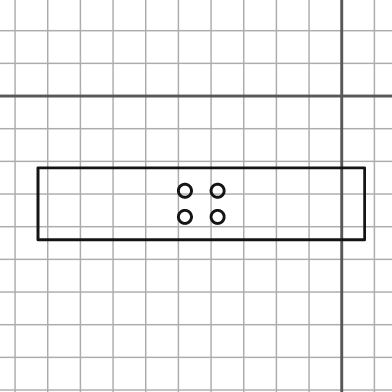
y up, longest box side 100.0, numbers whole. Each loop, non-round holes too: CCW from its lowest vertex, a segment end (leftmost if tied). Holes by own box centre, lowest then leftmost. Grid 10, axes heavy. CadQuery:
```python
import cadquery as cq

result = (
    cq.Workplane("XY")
    .moveTo(-93.0, -44.0)
    .lineTo(7.0, -44.0)
    .lineTo(7.0, -22.0)
    .lineTo(-93.0, -22.0)
    .close()
    .moveTo(-48.0, -37.0)
    .circle(2.0)
    .moveTo(-38.0, -37.0)
    .circle(2.0)
    .moveTo(-48.0, -29.0)
    .circle(2.0)
    .moveTo(-38.0, -29.0)
    .circle(2.0)
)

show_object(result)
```